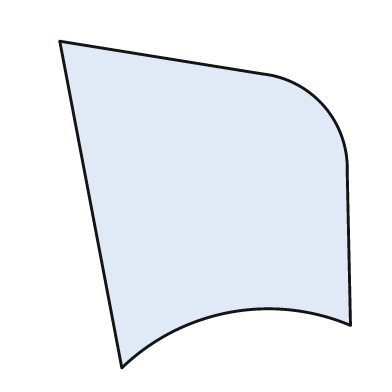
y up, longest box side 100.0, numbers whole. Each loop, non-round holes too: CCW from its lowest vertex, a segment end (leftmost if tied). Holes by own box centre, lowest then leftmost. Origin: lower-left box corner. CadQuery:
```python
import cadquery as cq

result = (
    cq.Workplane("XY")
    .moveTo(19.0, 0.0)
    .threePointArc((52.0, 17.0), (89.0, 13.0))
    .lineTo(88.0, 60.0)
    .threePointArc((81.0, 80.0), (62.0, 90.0))
    .lineTo(0.0, 100.0)
    .close()
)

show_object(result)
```